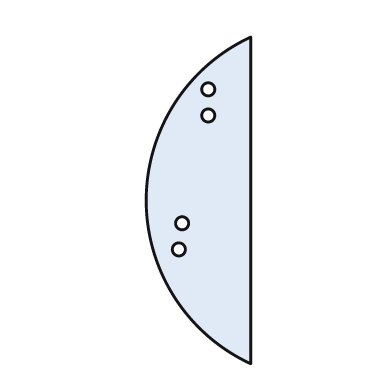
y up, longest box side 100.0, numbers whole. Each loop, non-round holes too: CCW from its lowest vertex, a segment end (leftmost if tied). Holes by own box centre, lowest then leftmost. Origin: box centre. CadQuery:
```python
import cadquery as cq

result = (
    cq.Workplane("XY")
    .moveTo(16.0, -50.0)
    .lineTo(16.0, 50.0)
    .threePointArc((-16.0, 0.0), (16.0, -50.0))
    .close()
    .moveTo(-6.0, -15.0)
    .circle(2.0)
    .moveTo(-5.0, -7.0)
    .circle(2.0)
    .moveTo(3.0, 26.0)
    .circle(2.0)
    .moveTo(3.0, 34.0)
    .circle(2.0)
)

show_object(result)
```